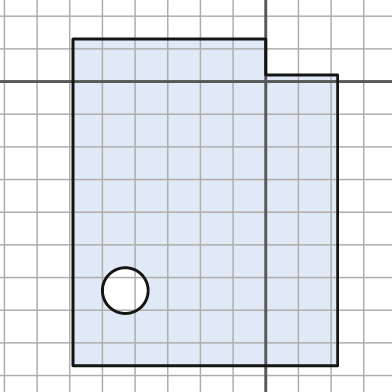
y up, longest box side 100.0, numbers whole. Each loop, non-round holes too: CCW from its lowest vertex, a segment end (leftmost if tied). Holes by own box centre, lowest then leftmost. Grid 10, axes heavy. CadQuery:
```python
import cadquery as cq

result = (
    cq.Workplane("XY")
    .moveTo(-59.0, -87.0)
    .lineTo(22.0, -87.0)
    .lineTo(22.0, 2.0)
    .lineTo(0.0, 2.0)
    .lineTo(0.0, 13.0)
    .lineTo(-59.0, 13.0)
    .close()
    .moveTo(-43.0, -64.0)
    .circle(7.0)
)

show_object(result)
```